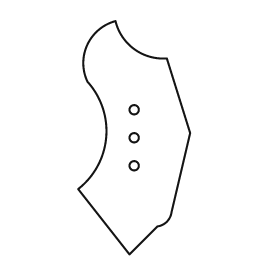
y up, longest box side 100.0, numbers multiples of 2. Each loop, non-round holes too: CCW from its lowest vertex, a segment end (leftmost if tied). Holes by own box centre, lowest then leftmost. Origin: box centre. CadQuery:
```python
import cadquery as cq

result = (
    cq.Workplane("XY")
    .moveTo(-2.0, -50.0)
    .lineTo(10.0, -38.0)
    .threePointArc((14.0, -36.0), (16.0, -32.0))
    .lineTo(24.0, 2.0)
    .lineTo(14.0, 34.0)
    .threePointArc((0.0, 38.0), (-8.0, 50.0))
    .threePointArc((-20.0, 40.0), (-20.0, 24.0))
    .threePointArc((-12.0, 0.0), (-24.0, -22.0))
    .close()
    .moveTo(0.0, -12.0)
    .circle(2.0)
    .moveTo(0.0, 0.0)
    .circle(2.0)
    .moveTo(0.0, 12.0)
    .circle(2.0)
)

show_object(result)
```